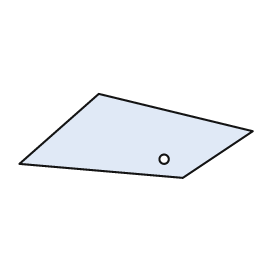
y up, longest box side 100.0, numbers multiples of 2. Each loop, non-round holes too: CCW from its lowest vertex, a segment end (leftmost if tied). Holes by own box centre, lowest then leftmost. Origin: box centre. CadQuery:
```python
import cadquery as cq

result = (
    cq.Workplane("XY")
    .moveTo(20.0, -18.0)
    .lineTo(50.0, 2.0)
    .lineTo(-16.0, 18.0)
    .lineTo(-50.0, -12.0)
    .close()
    .moveTo(12.0, -10.0)
    .circle(2.0)
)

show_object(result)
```